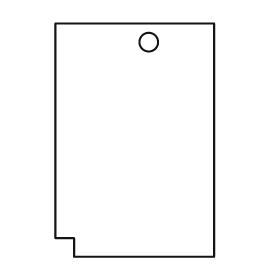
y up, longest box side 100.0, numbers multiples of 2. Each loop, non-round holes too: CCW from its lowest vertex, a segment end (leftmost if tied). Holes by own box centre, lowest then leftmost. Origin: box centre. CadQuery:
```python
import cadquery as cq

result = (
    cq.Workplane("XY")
    .moveTo(-26.0, -50.0)
    .lineTo(34.0, -50.0)
    .lineTo(34.0, 50.0)
    .lineTo(-34.0, 50.0)
    .lineTo(-34.0, -42.0)
    .lineTo(-26.0, -42.0)
    .close()
    .moveTo(6.0, 42.0)
    .circle(4.0)
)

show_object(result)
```